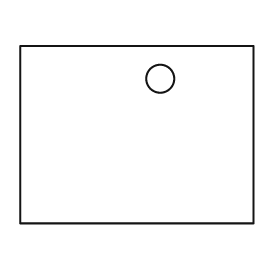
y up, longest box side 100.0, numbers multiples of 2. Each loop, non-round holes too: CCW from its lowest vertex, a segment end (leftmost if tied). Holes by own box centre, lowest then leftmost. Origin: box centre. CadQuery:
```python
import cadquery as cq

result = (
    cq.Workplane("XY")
    .moveTo(-50.0, -38.0)
    .lineTo(50.0, -38.0)
    .lineTo(50.0, 38.0)
    .lineTo(-50.0, 38.0)
    .close()
    .moveTo(10.0, 24.0)
    .circle(6.0)
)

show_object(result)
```